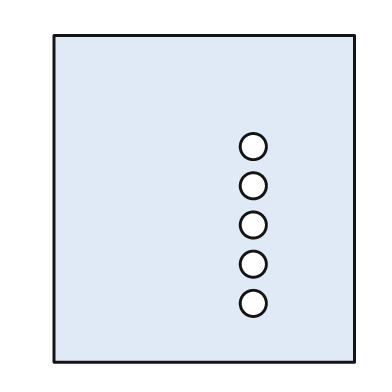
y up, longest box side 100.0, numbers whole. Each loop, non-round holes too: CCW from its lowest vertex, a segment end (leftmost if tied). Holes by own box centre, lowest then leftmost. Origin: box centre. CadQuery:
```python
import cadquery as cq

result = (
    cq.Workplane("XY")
    .moveTo(-46.0, -50.0)
    .lineTo(46.0, -50.0)
    .lineTo(46.0, 50.0)
    .lineTo(-46.0, 50.0)
    .close()
    .moveTo(15.0, -32.0)
    .circle(4.0)
    .moveTo(15.0, -20.0)
    .circle(4.0)
    .moveTo(15.0, -8.0)
    .circle(4.0)
    .moveTo(15.0, 4.0)
    .circle(4.0)
    .moveTo(15.0, 16.0)
    .circle(4.0)
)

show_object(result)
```